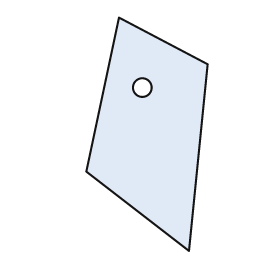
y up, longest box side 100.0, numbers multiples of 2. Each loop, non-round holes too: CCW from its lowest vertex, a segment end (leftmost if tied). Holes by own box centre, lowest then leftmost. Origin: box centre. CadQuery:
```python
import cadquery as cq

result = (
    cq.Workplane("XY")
    .moveTo(18.0, -50.0)
    .lineTo(26.0, 30.0)
    .lineTo(-12.0, 50.0)
    .lineTo(-26.0, -16.0)
    .close()
    .moveTo(-2.0, 20.0)
    .circle(4.0)
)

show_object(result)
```